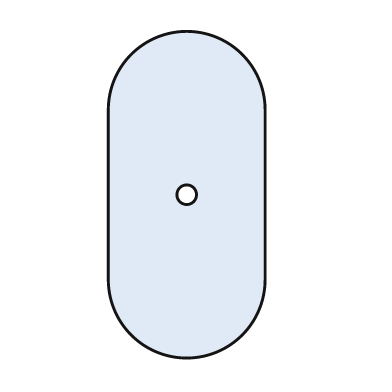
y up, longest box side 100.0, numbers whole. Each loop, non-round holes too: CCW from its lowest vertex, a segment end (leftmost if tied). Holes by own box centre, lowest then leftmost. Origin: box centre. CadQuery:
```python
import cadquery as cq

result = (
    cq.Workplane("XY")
    .moveTo(-24.0, -26.0)
    .threePointArc((0.0, -50.0), (24.0, -26.0))
    .lineTo(24.0, 26.0)
    .threePointArc((0.0, 50.0), (-24.0, 26.0))
    .close()
    .moveTo(0.0, 0.0)
    .circle(3.0)
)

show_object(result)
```